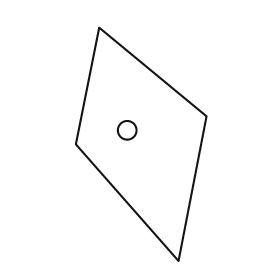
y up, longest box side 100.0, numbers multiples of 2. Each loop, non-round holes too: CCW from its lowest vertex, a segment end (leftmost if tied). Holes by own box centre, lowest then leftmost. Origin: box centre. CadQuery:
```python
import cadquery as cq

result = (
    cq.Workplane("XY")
    .moveTo(16.0, -50.0)
    .lineTo(28.0, 12.0)
    .lineTo(-18.0, 50.0)
    .lineTo(-28.0, 0.0)
    .close()
    .moveTo(-6.0, 6.0)
    .circle(4.0)
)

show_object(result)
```